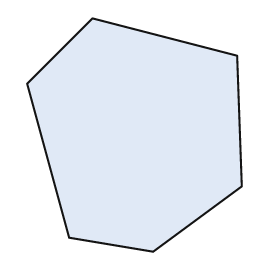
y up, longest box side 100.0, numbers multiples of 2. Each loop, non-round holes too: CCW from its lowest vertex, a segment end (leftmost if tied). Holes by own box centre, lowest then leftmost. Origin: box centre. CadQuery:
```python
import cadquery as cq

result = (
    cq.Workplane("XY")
    .moveTo(8.0, -50.0)
    .lineTo(46.0, -22.0)
    .lineTo(44.0, 34.0)
    .lineTo(-18.0, 50.0)
    .lineTo(-46.0, 22.0)
    .lineTo(-28.0, -44.0)
    .close()
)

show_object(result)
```